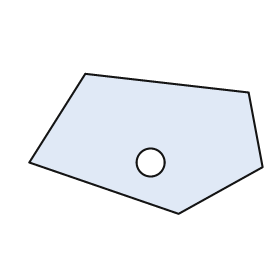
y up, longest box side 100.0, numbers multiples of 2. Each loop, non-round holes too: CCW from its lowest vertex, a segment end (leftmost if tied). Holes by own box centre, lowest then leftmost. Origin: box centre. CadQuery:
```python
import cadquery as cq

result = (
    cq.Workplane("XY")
    .moveTo(14.0, -30.0)
    .lineTo(50.0, -10.0)
    .lineTo(44.0, 22.0)
    .lineTo(-26.0, 30.0)
    .lineTo(-50.0, -8.0)
    .close()
    .moveTo(2.0, -8.0)
    .circle(6.0)
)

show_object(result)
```